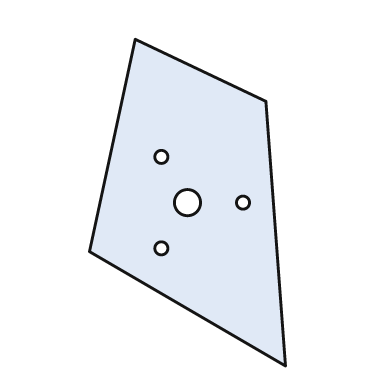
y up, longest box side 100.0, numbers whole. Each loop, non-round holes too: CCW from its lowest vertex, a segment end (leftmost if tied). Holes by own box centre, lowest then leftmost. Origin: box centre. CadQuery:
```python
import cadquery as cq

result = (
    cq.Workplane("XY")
    .moveTo(30.0, -50.0)
    .lineTo(24.0, 31.0)
    .lineTo(-16.0, 50.0)
    .lineTo(-30.0, -15.0)
    .close()
    .moveTo(-8.0, -14.0)
    .circle(2.0)
    .moveTo(0.0, 0.0)
    .circle(4.0)
    .moveTo(17.0, 0.0)
    .circle(2.0)
    .moveTo(-8.0, 14.0)
    .circle(2.0)
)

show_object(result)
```